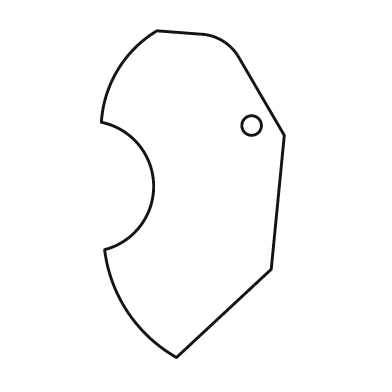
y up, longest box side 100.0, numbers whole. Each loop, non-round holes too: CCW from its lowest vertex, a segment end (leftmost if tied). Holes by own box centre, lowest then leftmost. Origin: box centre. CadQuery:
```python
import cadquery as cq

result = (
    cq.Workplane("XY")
    .moveTo(-5.0, -50.0)
    .lineTo(24.0, -23.0)
    .lineTo(28.0, 18.0)
    .lineTo(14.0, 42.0)
    .threePointArc((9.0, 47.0), (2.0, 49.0))
    .lineTo(-11.0, 50.0)
    .threePointArc((-23.0, 38.0), (-28.0, 22.0))
    .threePointArc((-12.0, 3.0), (-27.0, -17.0))
    .threePointArc((-20.0, -36.0), (-5.0, -50.0))
    .close()
    .moveTo(18.0, 21.0)
    .circle(3.0)
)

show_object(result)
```